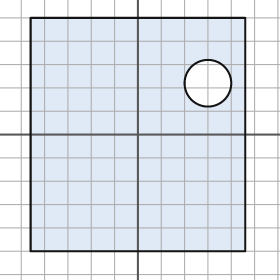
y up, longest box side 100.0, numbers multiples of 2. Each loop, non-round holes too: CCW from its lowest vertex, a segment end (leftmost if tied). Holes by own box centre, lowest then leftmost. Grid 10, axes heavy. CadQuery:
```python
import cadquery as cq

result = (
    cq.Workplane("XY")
    .moveTo(-46.0, -50.0)
    .lineTo(46.0, -50.0)
    .lineTo(46.0, 50.0)
    .lineTo(-46.0, 50.0)
    .close()
    .moveTo(30.0, 22.0)
    .circle(10.0)
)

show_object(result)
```